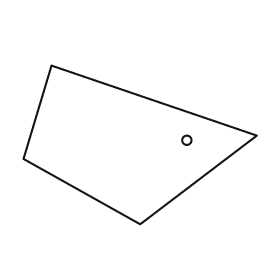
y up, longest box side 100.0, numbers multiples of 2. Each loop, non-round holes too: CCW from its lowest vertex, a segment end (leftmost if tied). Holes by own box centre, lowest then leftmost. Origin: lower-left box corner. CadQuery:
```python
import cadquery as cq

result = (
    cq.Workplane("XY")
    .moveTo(50.0, 0.0)
    .lineTo(100.0, 38.0)
    .lineTo(12.0, 68.0)
    .lineTo(0.0, 28.0)
    .close()
    .moveTo(70.0, 36.0)
    .circle(2.0)
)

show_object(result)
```